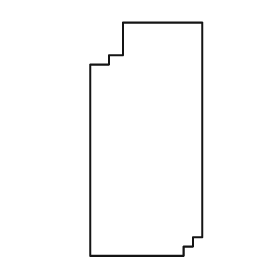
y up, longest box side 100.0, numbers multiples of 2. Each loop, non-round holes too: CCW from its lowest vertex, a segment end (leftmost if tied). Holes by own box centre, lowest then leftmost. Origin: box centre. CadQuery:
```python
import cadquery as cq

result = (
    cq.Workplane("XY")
    .moveTo(-24.0, -50.0)
    .lineTo(16.0, -50.0)
    .lineTo(16.0, -46.0)
    .lineTo(20.0, -46.0)
    .lineTo(20.0, -42.0)
    .lineTo(24.0, -42.0)
    .lineTo(24.0, 50.0)
    .lineTo(-10.0, 50.0)
    .lineTo(-10.0, 36.0)
    .lineTo(-16.0, 36.0)
    .lineTo(-16.0, 32.0)
    .lineTo(-24.0, 32.0)
    .close()
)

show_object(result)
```